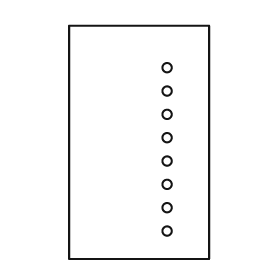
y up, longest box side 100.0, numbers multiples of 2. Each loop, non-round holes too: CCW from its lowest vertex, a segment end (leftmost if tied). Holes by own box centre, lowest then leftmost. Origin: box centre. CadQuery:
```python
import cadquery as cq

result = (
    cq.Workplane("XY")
    .moveTo(-30.0, -50.0)
    .lineTo(30.0, -50.0)
    .lineTo(30.0, 50.0)
    .lineTo(-30.0, 50.0)
    .close()
    .moveTo(12.0, -38.0)
    .circle(2.0)
    .moveTo(12.0, -28.0)
    .circle(2.0)
    .moveTo(12.0, -18.0)
    .circle(2.0)
    .moveTo(12.0, -8.0)
    .circle(2.0)
    .moveTo(12.0, 2.0)
    .circle(2.0)
    .moveTo(12.0, 12.0)
    .circle(2.0)
    .moveTo(12.0, 22.0)
    .circle(2.0)
    .moveTo(12.0, 32.0)
    .circle(2.0)
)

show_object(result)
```